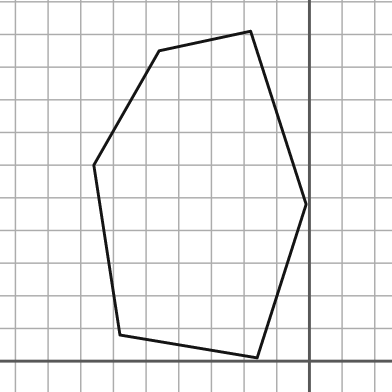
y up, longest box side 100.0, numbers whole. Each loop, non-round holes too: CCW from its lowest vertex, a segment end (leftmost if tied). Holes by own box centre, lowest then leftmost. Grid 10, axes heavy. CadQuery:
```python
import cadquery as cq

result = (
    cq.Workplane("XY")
    .moveTo(-16.0, 1.0)
    .lineTo(-1.0, 48.0)
    .lineTo(-18.0, 101.0)
    .lineTo(-46.0, 95.0)
    .lineTo(-66.0, 60.0)
    .lineTo(-58.0, 8.0)
    .close()
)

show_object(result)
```